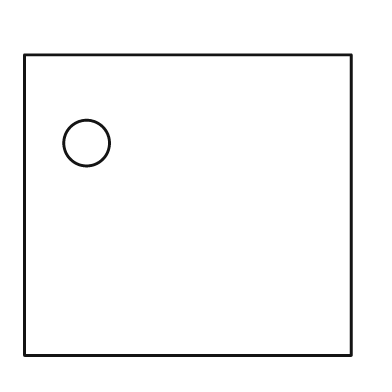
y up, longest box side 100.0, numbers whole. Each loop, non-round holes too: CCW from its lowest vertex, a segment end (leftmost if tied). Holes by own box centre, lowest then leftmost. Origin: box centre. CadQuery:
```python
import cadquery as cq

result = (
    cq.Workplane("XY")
    .moveTo(-50.0, -46.0)
    .lineTo(50.0, -46.0)
    .lineTo(50.0, 46.0)
    .lineTo(-50.0, 46.0)
    .close()
    .moveTo(-31.0, 19.0)
    .circle(7.0)
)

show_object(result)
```